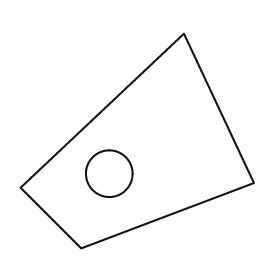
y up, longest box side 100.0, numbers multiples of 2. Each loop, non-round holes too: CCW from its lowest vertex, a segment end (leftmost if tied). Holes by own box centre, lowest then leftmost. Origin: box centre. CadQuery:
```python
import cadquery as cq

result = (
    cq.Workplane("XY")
    .moveTo(-24.0, -46.0)
    .lineTo(50.0, -18.0)
    .lineTo(20.0, 46.0)
    .lineTo(-50.0, -20.0)
    .close()
    .moveTo(-12.0, -14.0)
    .circle(10.0)
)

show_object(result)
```